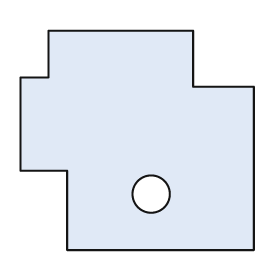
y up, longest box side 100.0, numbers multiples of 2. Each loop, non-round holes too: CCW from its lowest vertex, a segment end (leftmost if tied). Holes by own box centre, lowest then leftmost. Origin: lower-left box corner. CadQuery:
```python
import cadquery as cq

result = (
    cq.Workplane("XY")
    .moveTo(20.0, 0.0)
    .lineTo(100.0, 0.0)
    .lineTo(100.0, 70.0)
    .lineTo(74.0, 70.0)
    .lineTo(74.0, 94.0)
    .lineTo(12.0, 94.0)
    .lineTo(12.0, 74.0)
    .lineTo(0.0, 74.0)
    .lineTo(0.0, 34.0)
    .lineTo(20.0, 34.0)
    .close()
    .moveTo(56.0, 24.0)
    .circle(8.0)
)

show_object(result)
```